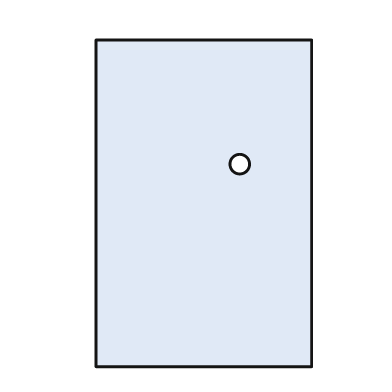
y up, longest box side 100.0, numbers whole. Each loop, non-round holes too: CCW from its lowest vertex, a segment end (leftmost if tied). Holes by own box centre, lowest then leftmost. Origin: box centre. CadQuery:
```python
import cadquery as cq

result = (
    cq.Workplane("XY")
    .moveTo(-33.0, -50.0)
    .lineTo(33.0, -50.0)
    .lineTo(33.0, 50.0)
    .lineTo(-33.0, 50.0)
    .close()
    .moveTo(11.0, 12.0)
    .circle(3.0)
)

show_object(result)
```